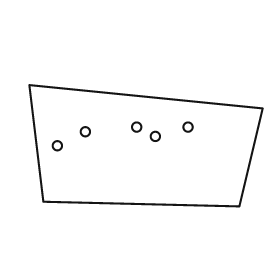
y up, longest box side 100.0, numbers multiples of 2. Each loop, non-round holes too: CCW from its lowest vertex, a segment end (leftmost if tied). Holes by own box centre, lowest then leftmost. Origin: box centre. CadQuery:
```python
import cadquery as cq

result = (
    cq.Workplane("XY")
    .moveTo(40.0, -26.0)
    .lineTo(50.0, 16.0)
    .lineTo(-50.0, 26.0)
    .lineTo(-44.0, -24.0)
    .close()
    .moveTo(-38.0, 0.0)
    .circle(2.0)
    .moveTo(4.0, 4.0)
    .circle(2.0)
    .moveTo(-26.0, 6.0)
    .circle(2.0)
    .moveTo(-4.0, 8.0)
    .circle(2.0)
    .moveTo(18.0, 8.0)
    .circle(2.0)
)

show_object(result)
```